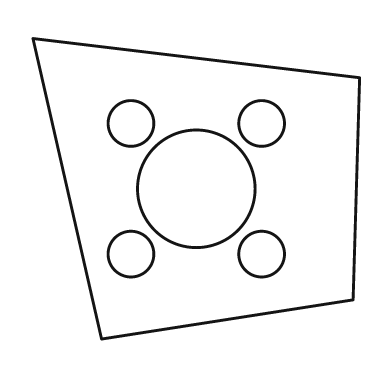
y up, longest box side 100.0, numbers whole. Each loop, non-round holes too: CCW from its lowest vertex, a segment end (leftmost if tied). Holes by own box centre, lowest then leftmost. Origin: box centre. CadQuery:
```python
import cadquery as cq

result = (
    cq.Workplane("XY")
    .moveTo(-29.0, -46.0)
    .lineTo(48.0, -34.0)
    .lineTo(50.0, 34.0)
    .lineTo(-50.0, 46.0)
    .close()
    .moveTo(-20.0, -20.0)
    .circle(7.0)
    .moveTo(20.0, -20.0)
    .circle(7.0)
    .moveTo(0.0, 0.0)
    .circle(18.0)
    .moveTo(-20.0, 20.0)
    .circle(7.0)
    .moveTo(20.0, 20.0)
    .circle(7.0)
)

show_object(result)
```